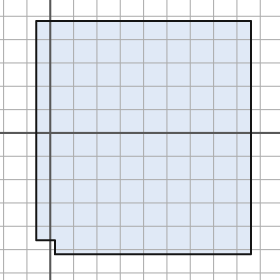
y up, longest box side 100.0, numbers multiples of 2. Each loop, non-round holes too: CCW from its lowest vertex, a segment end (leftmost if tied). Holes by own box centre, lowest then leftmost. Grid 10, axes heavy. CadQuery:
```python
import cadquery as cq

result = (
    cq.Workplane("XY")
    .moveTo(2.0, -52.0)
    .lineTo(86.0, -52.0)
    .lineTo(86.0, 48.0)
    .lineTo(-6.0, 48.0)
    .lineTo(-6.0, -46.0)
    .lineTo(2.0, -46.0)
    .close()
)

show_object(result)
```